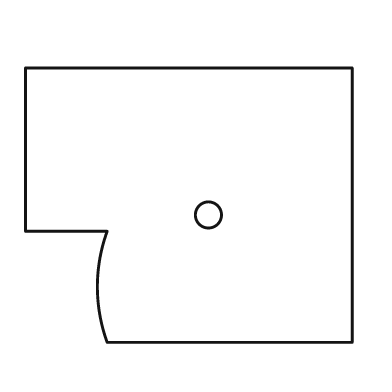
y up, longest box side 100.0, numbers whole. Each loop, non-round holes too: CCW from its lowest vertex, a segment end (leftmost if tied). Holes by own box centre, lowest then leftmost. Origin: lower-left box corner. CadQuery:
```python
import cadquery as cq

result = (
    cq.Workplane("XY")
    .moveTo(25.0, 0.0)
    .lineTo(100.0, 0.0)
    .lineTo(100.0, 84.0)
    .lineTo(0.0, 84.0)
    .lineTo(0.0, 34.0)
    .lineTo(25.0, 34.0)
    .threePointArc((22.0, 17.0), (25.0, 0.0))
    .close()
    .moveTo(56.0, 39.0)
    .circle(4.0)
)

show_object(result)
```